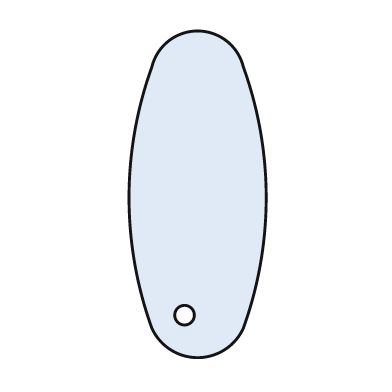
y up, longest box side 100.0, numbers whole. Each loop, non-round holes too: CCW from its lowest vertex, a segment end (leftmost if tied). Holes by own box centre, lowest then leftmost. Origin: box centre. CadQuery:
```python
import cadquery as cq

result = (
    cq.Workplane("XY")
    .moveTo(-14.0, -41.0)
    .threePointArc((0.0, -50.0), (14.0, -41.0))
    .threePointArc((21.0, -1.0), (14.0, 39.0))
    .threePointArc((0.0, 50.0), (-14.0, 39.0))
    .threePointArc((-21.0, -1.0), (-14.0, -41.0))
    .close()
    .moveTo(-4.0, -37.0)
    .circle(3.0)
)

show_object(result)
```